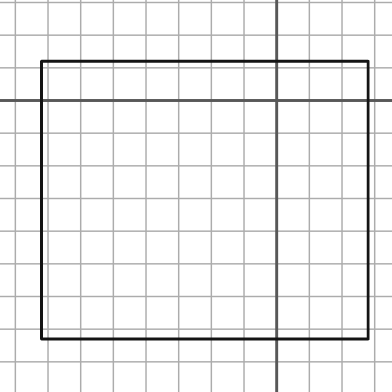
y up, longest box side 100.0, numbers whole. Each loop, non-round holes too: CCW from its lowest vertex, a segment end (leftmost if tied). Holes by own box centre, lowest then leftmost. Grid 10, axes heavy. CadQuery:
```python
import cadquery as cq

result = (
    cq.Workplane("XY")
    .moveTo(-72.0, -73.0)
    .lineTo(28.0, -73.0)
    .lineTo(28.0, 12.0)
    .lineTo(-72.0, 12.0)
    .close()
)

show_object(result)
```